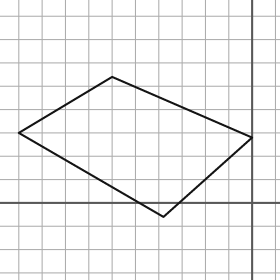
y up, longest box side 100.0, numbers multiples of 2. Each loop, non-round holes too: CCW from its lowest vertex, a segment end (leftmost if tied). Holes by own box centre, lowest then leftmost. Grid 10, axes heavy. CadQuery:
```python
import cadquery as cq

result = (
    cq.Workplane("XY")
    .moveTo(-38.0, -6.0)
    .lineTo(0.0, 28.0)
    .lineTo(-60.0, 54.0)
    .lineTo(-100.0, 30.0)
    .close()
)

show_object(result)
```